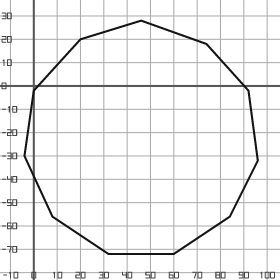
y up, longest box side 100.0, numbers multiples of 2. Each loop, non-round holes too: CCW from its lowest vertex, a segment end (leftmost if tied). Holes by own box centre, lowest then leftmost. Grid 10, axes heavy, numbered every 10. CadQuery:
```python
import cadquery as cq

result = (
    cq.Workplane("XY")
    .moveTo(32.0, -72.0)
    .lineTo(60.0, -72.0)
    .lineTo(84.0, -56.0)
    .lineTo(96.0, -32.0)
    .lineTo(92.0, -2.0)
    .lineTo(74.0, 18.0)
    .lineTo(46.0, 28.0)
    .lineTo(20.0, 20.0)
    .lineTo(0.0, -2.0)
    .lineTo(-4.0, -30.0)
    .lineTo(8.0, -56.0)
    .close()
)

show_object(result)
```